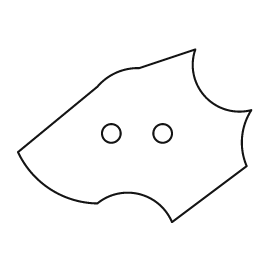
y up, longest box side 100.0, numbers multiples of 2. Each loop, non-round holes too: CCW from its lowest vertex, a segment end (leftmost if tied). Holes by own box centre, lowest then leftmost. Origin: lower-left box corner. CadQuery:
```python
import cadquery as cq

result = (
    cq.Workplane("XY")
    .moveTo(66.0, 0.0)
    .lineTo(98.0, 24.0)
    .threePointArc((96.0, 36.0), (100.0, 48.0))
    .threePointArc((80.0, 54.0), (76.0, 74.0))
    .lineTo(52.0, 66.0)
    .threePointArc((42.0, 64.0), (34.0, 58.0))
    .lineTo(0.0, 30.0)
    .threePointArc((14.0, 14.0), (34.0, 8.0))
    .threePointArc((52.0, 12.0), (66.0, 0.0))
    .close()
    .moveTo(40.0, 38.0)
    .circle(4.0)
    .moveTo(62.0, 38.0)
    .circle(4.0)
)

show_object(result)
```